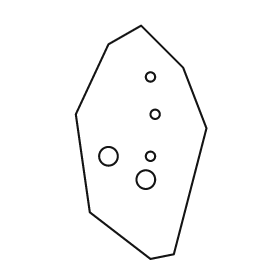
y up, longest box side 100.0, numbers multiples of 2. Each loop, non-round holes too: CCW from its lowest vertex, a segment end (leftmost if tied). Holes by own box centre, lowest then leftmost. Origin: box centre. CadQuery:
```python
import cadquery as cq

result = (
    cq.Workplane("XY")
    .moveTo(4.0, -50.0)
    .lineTo(14.0, -48.0)
    .lineTo(28.0, 6.0)
    .lineTo(18.0, 32.0)
    .lineTo(0.0, 50.0)
    .lineTo(-14.0, 42.0)
    .lineTo(-28.0, 12.0)
    .lineTo(-22.0, -30.0)
    .close()
    .moveTo(2.0, -16.0)
    .circle(4.0)
    .moveTo(-14.0, -6.0)
    .circle(4.0)
    .moveTo(4.0, -6.0)
    .circle(2.0)
    .moveTo(6.0, 12.0)
    .circle(2.0)
    .moveTo(4.0, 28.0)
    .circle(2.0)
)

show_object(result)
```